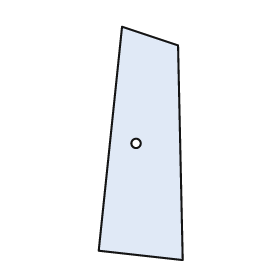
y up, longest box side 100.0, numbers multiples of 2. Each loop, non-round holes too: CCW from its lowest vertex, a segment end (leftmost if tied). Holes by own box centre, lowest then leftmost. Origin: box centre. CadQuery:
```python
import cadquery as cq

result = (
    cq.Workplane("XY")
    .moveTo(18.0, -50.0)
    .lineTo(16.0, 42.0)
    .lineTo(-8.0, 50.0)
    .lineTo(-18.0, -46.0)
    .close()
    .moveTo(-2.0, 0.0)
    .circle(2.0)
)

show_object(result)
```